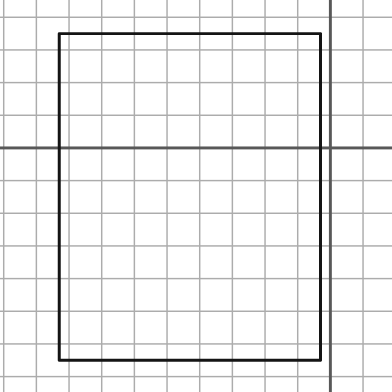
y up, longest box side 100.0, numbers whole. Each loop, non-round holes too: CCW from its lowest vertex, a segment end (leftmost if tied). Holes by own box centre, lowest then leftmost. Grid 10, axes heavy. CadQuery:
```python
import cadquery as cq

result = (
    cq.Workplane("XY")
    .moveTo(-83.0, -65.0)
    .lineTo(-3.0, -65.0)
    .lineTo(-3.0, 35.0)
    .lineTo(-83.0, 35.0)
    .close()
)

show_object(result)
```